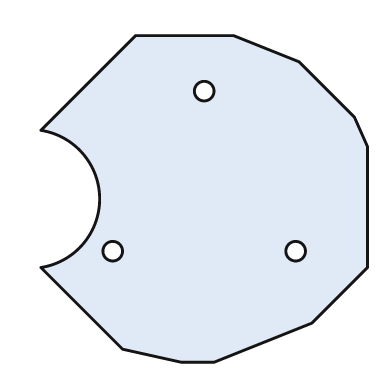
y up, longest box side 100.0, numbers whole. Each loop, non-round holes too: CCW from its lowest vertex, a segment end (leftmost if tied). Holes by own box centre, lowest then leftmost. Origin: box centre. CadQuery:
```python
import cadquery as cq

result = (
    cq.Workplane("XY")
    .moveTo(-7.0, -50.0)
    .lineTo(3.0, -50.0)
    .lineTo(33.0, -38.0)
    .lineTo(50.0, -21.0)
    .lineTo(50.0, 16.0)
    .lineTo(46.0, 25.0)
    .lineTo(29.0, 42.0)
    .lineTo(9.0, 50.0)
    .lineTo(-21.0, 50.0)
    .lineTo(-50.0, 21.0)
    .threePointArc((-32.0, 0.0), (-50.0, -21.0))
    .lineTo(-25.0, -46.0)
    .close()
    .moveTo(-28.0, -16.0)
    .circle(3.0)
    .moveTo(28.0, -16.0)
    .circle(3.0)
    .moveTo(0.0, 33.0)
    .circle(3.0)
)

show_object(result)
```